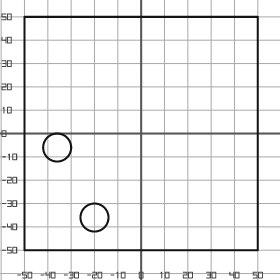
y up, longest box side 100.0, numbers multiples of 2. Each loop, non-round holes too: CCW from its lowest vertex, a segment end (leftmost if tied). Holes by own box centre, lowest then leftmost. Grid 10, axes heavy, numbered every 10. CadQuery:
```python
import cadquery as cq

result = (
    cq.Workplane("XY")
    .moveTo(-50.0, -50.0)
    .lineTo(50.0, -50.0)
    .lineTo(50.0, 50.0)
    .lineTo(-50.0, 50.0)
    .close()
    .moveTo(-20.0, -36.0)
    .circle(6.0)
    .moveTo(-36.0, -6.0)
    .circle(6.0)
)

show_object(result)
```